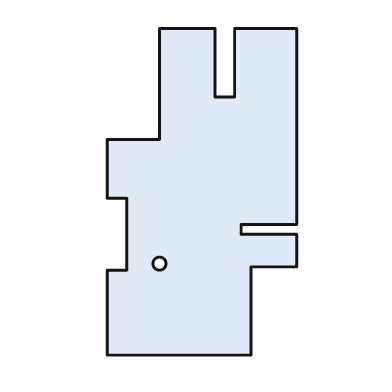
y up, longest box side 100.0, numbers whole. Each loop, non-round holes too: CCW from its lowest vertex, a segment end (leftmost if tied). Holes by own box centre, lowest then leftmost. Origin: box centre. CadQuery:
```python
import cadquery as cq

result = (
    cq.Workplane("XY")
    .moveTo(-29.0, -50.0)
    .lineTo(15.0, -50.0)
    .lineTo(15.0, -23.0)
    .lineTo(29.0, -23.0)
    .lineTo(29.0, -13.0)
    .lineTo(12.0, -13.0)
    .lineTo(12.0, -10.0)
    .lineTo(29.0, -10.0)
    .lineTo(29.0, 50.0)
    .lineTo(10.0, 50.0)
    .lineTo(10.0, 29.0)
    .lineTo(4.0, 29.0)
    .lineTo(4.0, 50.0)
    .lineTo(-13.0, 50.0)
    .lineTo(-13.0, 16.0)
    .lineTo(-29.0, 16.0)
    .lineTo(-29.0, -2.0)
    .lineTo(-23.0, -2.0)
    .lineTo(-23.0, -24.0)
    .lineTo(-29.0, -24.0)
    .close()
    .moveTo(-13.0, -22.0)
    .circle(2.0)
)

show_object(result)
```